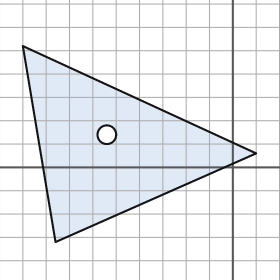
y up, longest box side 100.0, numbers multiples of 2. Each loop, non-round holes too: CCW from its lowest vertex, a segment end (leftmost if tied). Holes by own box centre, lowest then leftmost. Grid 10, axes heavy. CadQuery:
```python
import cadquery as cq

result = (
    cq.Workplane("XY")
    .moveTo(-76.0, -32.0)
    .lineTo(10.0, 6.0)
    .lineTo(-90.0, 52.0)
    .close()
    .moveTo(-54.0, 14.0)
    .circle(4.0)
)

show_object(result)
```